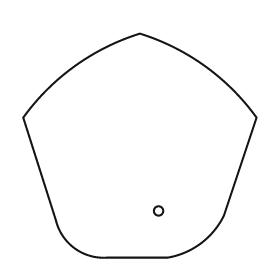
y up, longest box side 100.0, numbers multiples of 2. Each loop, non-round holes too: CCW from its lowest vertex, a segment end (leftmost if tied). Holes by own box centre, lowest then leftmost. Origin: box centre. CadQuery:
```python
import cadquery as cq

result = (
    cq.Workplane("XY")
    .moveTo(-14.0, -48.0)
    .lineTo(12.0, -48.0)
    .threePointArc((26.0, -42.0), (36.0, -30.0))
    .lineTo(50.0, 12.0)
    .threePointArc((28.0, 34.0), (0.0, 48.0))
    .threePointArc((-28.0, 34.0), (-50.0, 12.0))
    .lineTo(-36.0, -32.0)
    .threePointArc((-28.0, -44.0), (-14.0, -48.0))
    .close()
    .moveTo(8.0, -28.0)
    .circle(2.0)
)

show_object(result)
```